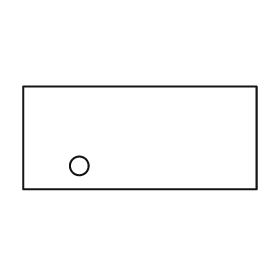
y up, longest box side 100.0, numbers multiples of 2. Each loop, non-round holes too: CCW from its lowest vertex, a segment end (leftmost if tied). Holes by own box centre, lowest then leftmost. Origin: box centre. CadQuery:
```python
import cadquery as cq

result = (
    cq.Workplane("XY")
    .moveTo(-50.0, -22.0)
    .lineTo(50.0, -22.0)
    .lineTo(50.0, 22.0)
    .lineTo(-50.0, 22.0)
    .close()
    .moveTo(-26.0, -12.0)
    .circle(4.0)
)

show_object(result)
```